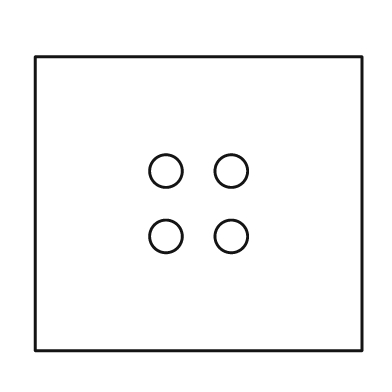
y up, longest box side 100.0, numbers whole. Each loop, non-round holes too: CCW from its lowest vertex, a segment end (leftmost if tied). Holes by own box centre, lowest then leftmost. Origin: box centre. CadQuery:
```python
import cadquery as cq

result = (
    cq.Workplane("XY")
    .moveTo(-50.0, -45.0)
    .lineTo(50.0, -45.0)
    .lineTo(50.0, 45.0)
    .lineTo(-50.0, 45.0)
    .close()
    .moveTo(-10.0, -10.0)
    .circle(5.0)
    .moveTo(10.0, -10.0)
    .circle(5.0)
    .moveTo(-10.0, 10.0)
    .circle(5.0)
    .moveTo(10.0, 10.0)
    .circle(5.0)
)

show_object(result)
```